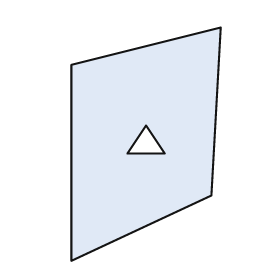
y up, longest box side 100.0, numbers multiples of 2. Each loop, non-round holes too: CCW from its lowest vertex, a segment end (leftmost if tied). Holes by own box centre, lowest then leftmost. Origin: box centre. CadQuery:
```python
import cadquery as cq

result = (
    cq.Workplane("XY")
    .moveTo(-32.0, -50.0)
    .lineTo(28.0, -22.0)
    .lineTo(32.0, 50.0)
    .lineTo(-32.0, 34.0)
    .close()
    .moveTo(-8.0, -4.0)
    .lineTo(8.0, -4.0)
    .lineTo(0.0, 8.0)
    .close()
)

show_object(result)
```